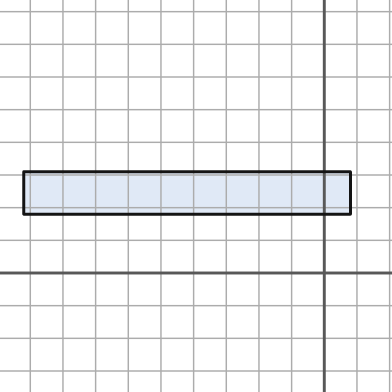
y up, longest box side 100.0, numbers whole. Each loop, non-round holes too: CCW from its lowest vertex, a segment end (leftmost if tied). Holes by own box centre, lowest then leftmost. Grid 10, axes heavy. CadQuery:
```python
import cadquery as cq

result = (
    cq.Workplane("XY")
    .moveTo(-92.0, 18.0)
    .lineTo(8.0, 18.0)
    .lineTo(8.0, 31.0)
    .lineTo(-92.0, 31.0)
    .close()
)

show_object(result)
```